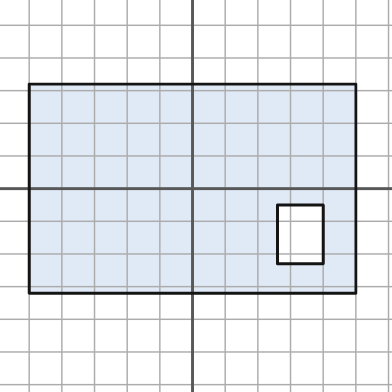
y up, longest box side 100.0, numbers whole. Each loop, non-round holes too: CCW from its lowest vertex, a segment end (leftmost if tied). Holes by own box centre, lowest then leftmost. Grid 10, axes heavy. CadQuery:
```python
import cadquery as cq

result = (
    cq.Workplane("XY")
    .moveTo(-50.0, -32.0)
    .lineTo(50.0, -32.0)
    .lineTo(50.0, 32.0)
    .lineTo(-50.0, 32.0)
    .close()
    .moveTo(26.0, -23.0)
    .lineTo(40.0, -23.0)
    .lineTo(40.0, -5.0)
    .lineTo(26.0, -5.0)
    .close()
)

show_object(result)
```